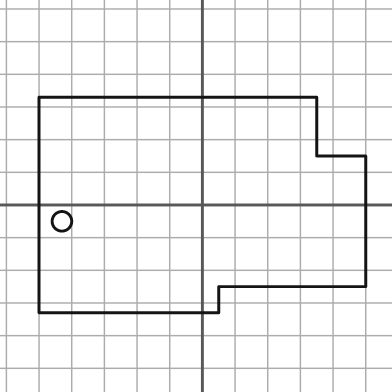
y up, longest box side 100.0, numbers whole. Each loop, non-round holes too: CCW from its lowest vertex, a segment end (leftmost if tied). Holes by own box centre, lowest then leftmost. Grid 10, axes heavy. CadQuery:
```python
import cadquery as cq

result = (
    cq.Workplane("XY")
    .moveTo(-50.0, -33.0)
    .lineTo(5.0, -33.0)
    .lineTo(5.0, -25.0)
    .lineTo(50.0, -25.0)
    .lineTo(50.0, 15.0)
    .lineTo(35.0, 15.0)
    .lineTo(35.0, 33.0)
    .lineTo(-50.0, 33.0)
    .close()
    .moveTo(-43.0, -5.0)
    .circle(3.0)
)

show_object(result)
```